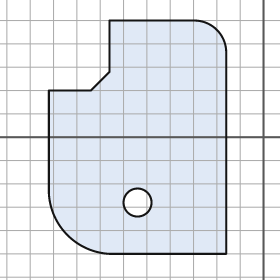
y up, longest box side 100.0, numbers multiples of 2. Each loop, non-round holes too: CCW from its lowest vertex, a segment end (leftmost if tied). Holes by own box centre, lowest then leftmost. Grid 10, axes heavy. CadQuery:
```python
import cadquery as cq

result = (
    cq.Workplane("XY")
    .moveTo(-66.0, -50.0)
    .lineTo(-16.0, -50.0)
    .lineTo(-16.0, 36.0)
    .threePointArc((-20.0, 46.0), (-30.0, 50.0))
    .lineTo(-66.0, 50.0)
    .lineTo(-66.0, 28.0)
    .lineTo(-74.0, 20.0)
    .lineTo(-92.0, 20.0)
    .lineTo(-92.0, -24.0)
    .threePointArc((-84.0, -42.0), (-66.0, -50.0))
    .close()
    .moveTo(-54.0, -28.0)
    .circle(6.0)
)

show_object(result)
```